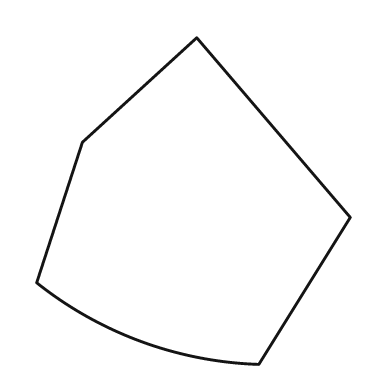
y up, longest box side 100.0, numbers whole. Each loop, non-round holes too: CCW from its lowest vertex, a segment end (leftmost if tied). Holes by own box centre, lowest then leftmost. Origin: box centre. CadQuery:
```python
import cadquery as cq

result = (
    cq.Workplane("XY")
    .moveTo(20.0, -50.0)
    .lineTo(48.0, -5.0)
    .lineTo(1.0, 50.0)
    .lineTo(-34.0, 18.0)
    .lineTo(-48.0, -25.0)
    .threePointArc((-16.0, -43.0), (20.0, -50.0))
    .close()
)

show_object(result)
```